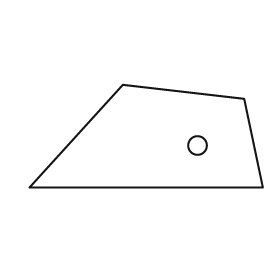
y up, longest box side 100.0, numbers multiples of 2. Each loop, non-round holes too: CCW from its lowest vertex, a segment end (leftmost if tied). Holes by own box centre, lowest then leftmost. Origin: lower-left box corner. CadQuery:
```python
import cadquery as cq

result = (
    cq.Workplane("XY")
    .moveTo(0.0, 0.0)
    .lineTo(100.0, 0.0)
    .lineTo(92.0, 38.0)
    .lineTo(40.0, 44.0)
    .close()
    .moveTo(72.0, 18.0)
    .circle(4.0)
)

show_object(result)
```